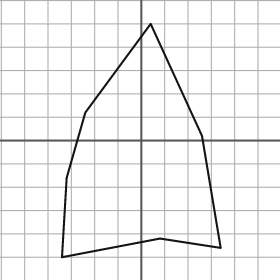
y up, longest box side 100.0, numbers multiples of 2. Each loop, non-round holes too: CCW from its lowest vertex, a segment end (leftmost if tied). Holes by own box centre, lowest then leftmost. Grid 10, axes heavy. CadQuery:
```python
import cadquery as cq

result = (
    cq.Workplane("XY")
    .moveTo(-34.0, -50.0)
    .lineTo(8.0, -42.0)
    .lineTo(34.0, -46.0)
    .lineTo(26.0, 2.0)
    .lineTo(4.0, 50.0)
    .lineTo(-24.0, 12.0)
    .lineTo(-32.0, -16.0)
    .close()
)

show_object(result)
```